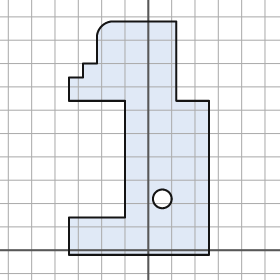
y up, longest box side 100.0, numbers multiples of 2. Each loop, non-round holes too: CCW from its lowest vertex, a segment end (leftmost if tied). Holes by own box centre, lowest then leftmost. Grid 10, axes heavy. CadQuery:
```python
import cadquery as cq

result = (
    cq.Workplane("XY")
    .moveTo(-34.0, -2.0)
    .lineTo(26.0, -2.0)
    .lineTo(26.0, 64.0)
    .lineTo(12.0, 64.0)
    .lineTo(12.0, 98.0)
    .lineTo(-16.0, 98.0)
    .threePointArc((-20.0, 96.0), (-22.0, 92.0))
    .lineTo(-22.0, 80.0)
    .lineTo(-28.0, 80.0)
    .lineTo(-28.0, 74.0)
    .lineTo(-34.0, 74.0)
    .lineTo(-34.0, 64.0)
    .lineTo(-10.0, 64.0)
    .lineTo(-10.0, 14.0)
    .lineTo(-34.0, 14.0)
    .close()
    .moveTo(6.0, 22.0)
    .circle(4.0)
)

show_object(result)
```